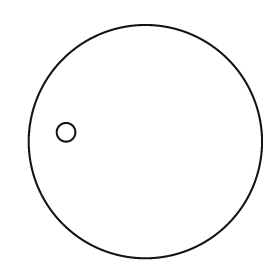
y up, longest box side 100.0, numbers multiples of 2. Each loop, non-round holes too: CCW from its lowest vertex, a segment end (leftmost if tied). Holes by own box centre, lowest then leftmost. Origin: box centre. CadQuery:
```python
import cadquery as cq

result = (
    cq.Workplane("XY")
    .moveTo(0.0, 0.0)
    .circle(50.0)
    .moveTo(-34.0, 4.0)
    .circle(4.0)
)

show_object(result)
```